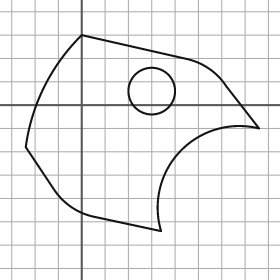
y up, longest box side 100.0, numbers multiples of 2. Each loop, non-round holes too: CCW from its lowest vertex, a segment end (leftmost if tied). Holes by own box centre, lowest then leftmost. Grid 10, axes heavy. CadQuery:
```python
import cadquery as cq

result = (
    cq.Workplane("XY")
    .moveTo(34.0, -54.0)
    .threePointArc((42.0, -20.0), (76.0, -10.0))
    .lineTo(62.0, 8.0)
    .threePointArc((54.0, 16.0), (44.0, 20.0))
    .lineTo(0.0, 30.0)
    .threePointArc((-16.0, 8.0), (-24.0, -18.0))
    .lineTo(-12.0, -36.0)
    .threePointArc((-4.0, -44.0), (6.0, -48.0))
    .close()
    .moveTo(30.0, 6.0)
    .circle(10.0)
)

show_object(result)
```